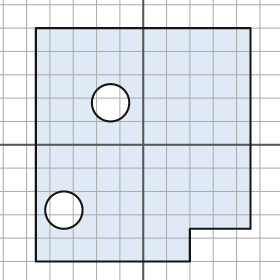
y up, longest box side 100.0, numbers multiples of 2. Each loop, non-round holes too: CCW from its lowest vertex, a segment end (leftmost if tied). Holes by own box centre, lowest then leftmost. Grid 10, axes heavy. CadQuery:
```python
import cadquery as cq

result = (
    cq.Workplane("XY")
    .moveTo(-46.0, -50.0)
    .lineTo(20.0, -50.0)
    .lineTo(20.0, -36.0)
    .lineTo(46.0, -36.0)
    .lineTo(46.0, 50.0)
    .lineTo(-46.0, 50.0)
    .close()
    .moveTo(-34.0, -28.0)
    .circle(8.0)
    .moveTo(-14.0, 18.0)
    .circle(8.0)
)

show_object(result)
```